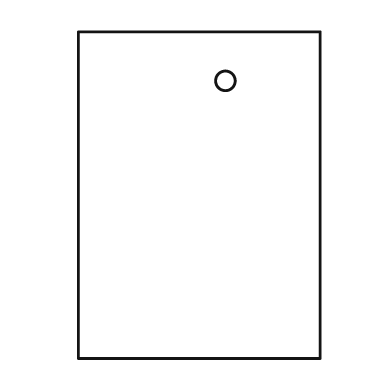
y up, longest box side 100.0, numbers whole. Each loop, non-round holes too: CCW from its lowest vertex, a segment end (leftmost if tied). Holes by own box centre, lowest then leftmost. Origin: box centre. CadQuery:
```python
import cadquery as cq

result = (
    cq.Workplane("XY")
    .moveTo(-37.0, -50.0)
    .lineTo(37.0, -50.0)
    .lineTo(37.0, 50.0)
    .lineTo(-37.0, 50.0)
    .close()
    .moveTo(8.0, 35.0)
    .circle(3.0)
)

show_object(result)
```